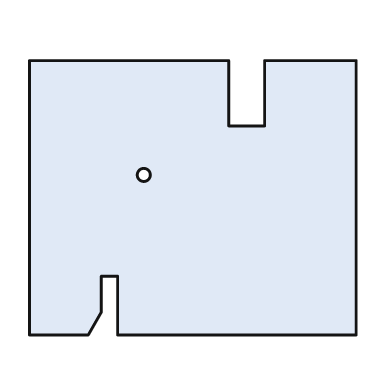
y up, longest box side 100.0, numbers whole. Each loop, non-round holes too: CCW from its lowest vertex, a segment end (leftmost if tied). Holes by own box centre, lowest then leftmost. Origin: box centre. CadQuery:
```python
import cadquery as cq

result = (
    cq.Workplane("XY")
    .moveTo(-50.0, -42.0)
    .lineTo(-32.0, -42.0)
    .lineTo(-28.0, -35.0)
    .lineTo(-28.0, -24.0)
    .lineTo(-23.0, -24.0)
    .lineTo(-23.0, -42.0)
    .lineTo(50.0, -42.0)
    .lineTo(50.0, 42.0)
    .lineTo(22.0, 42.0)
    .lineTo(22.0, 22.0)
    .lineTo(11.0, 22.0)
    .lineTo(11.0, 42.0)
    .lineTo(-50.0, 42.0)
    .close()
    .moveTo(-15.0, 7.0)
    .circle(2.0)
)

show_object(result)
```